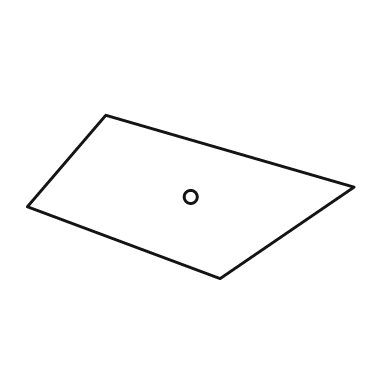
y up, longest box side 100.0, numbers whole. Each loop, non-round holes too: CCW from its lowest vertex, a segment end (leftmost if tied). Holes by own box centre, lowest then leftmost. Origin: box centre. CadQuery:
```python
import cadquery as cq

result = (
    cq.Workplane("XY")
    .moveTo(9.0, -25.0)
    .lineTo(50.0, 3.0)
    .lineTo(-26.0, 25.0)
    .lineTo(-50.0, -3.0)
    .close()
    .moveTo(0.0, 0.0)
    .circle(2.0)
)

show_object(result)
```